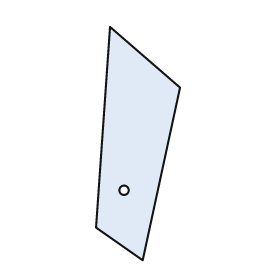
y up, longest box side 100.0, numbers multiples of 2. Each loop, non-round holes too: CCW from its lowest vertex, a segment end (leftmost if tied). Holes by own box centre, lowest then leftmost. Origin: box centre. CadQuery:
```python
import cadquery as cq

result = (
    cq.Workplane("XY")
    .moveTo(2.0, -50.0)
    .lineTo(18.0, 24.0)
    .lineTo(-12.0, 50.0)
    .lineTo(-18.0, -36.0)
    .close()
    .moveTo(-6.0, -20.0)
    .circle(2.0)
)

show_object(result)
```